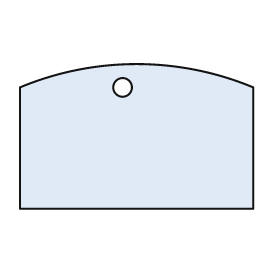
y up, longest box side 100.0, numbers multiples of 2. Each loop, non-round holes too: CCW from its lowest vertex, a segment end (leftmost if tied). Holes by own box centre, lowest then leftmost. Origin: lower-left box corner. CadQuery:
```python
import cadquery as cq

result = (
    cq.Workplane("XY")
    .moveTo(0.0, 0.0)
    .lineTo(100.0, 0.0)
    .lineTo(100.0, 52.0)
    .threePointArc((50.0, 62.0), (0.0, 52.0))
    .close()
    .moveTo(44.0, 52.0)
    .circle(4.0)
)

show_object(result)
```